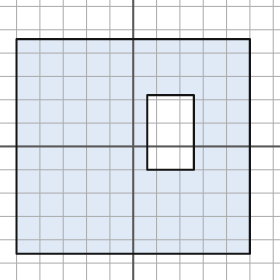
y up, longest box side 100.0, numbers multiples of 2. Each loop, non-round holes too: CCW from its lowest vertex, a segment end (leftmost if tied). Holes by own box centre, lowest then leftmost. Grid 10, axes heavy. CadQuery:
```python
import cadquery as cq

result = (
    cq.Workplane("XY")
    .moveTo(-50.0, -46.0)
    .lineTo(50.0, -46.0)
    .lineTo(50.0, 46.0)
    .lineTo(-50.0, 46.0)
    .close()
    .moveTo(6.0, -10.0)
    .lineTo(26.0, -10.0)
    .lineTo(26.0, 22.0)
    .lineTo(6.0, 22.0)
    .close()
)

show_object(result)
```